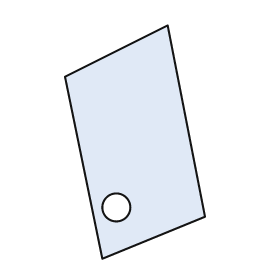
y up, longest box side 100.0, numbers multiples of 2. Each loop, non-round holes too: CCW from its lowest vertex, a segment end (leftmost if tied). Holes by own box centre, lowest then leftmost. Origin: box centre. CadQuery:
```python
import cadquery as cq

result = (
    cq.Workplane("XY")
    .moveTo(-14.0, -50.0)
    .lineTo(30.0, -32.0)
    .lineTo(14.0, 50.0)
    .lineTo(-30.0, 28.0)
    .close()
    .moveTo(-8.0, -28.0)
    .circle(6.0)
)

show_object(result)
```